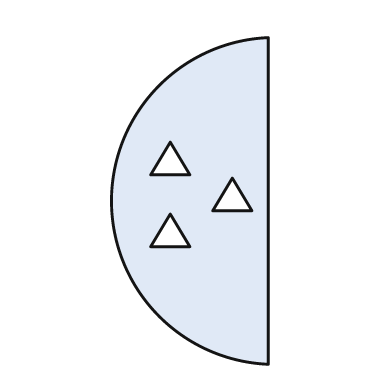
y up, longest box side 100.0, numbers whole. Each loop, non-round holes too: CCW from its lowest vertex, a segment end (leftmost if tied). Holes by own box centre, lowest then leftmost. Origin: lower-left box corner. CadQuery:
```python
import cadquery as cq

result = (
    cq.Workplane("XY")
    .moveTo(48.0, 0.0)
    .lineTo(48.0, 100.0)
    .threePointArc((0.0, 50.0), (48.0, 0.0))
    .close()
    .moveTo(12.0, 36.0)
    .lineTo(24.0, 36.0)
    .lineTo(18.0, 46.0)
    .close()
    .moveTo(31.0, 47.0)
    .lineTo(43.0, 47.0)
    .lineTo(37.0, 57.0)
    .close()
    .moveTo(12.0, 58.0)
    .lineTo(24.0, 58.0)
    .lineTo(18.0, 68.0)
    .close()
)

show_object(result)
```